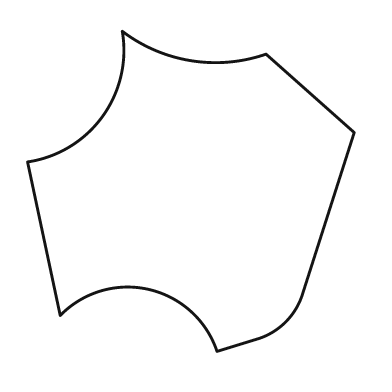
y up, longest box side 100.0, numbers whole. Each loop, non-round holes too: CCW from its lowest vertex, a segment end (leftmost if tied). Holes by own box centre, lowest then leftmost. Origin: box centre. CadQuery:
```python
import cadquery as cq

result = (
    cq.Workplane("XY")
    .moveTo(8.0, -49.0)
    .lineTo(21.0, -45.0)
    .threePointArc((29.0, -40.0), (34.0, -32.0))
    .lineTo(50.0, 18.0)
    .lineTo(23.0, 42.0)
    .threePointArc((0.0, 40.0), (-21.0, 49.0))
    .threePointArc((-27.0, 23.0), (-50.0, 9.0))
    .lineTo(-40.0, -38.0)
    .threePointArc((-13.0, -30.0), (8.0, -49.0))
    .close()
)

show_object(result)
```